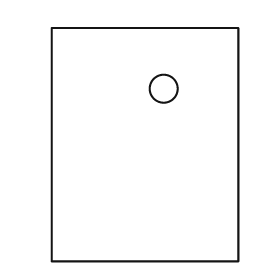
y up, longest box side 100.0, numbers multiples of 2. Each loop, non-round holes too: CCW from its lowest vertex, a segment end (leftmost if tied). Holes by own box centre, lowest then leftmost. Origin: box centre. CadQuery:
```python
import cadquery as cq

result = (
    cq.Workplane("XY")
    .moveTo(-40.0, -50.0)
    .lineTo(40.0, -50.0)
    .lineTo(40.0, 50.0)
    .lineTo(-40.0, 50.0)
    .close()
    .moveTo(8.0, 24.0)
    .circle(6.0)
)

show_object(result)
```